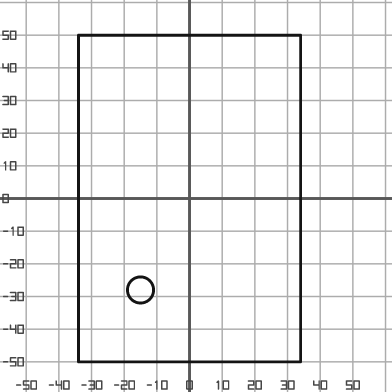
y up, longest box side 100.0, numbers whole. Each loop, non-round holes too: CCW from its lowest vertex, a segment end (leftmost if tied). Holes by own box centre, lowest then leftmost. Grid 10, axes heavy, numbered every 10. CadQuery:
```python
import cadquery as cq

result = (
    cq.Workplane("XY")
    .moveTo(-34.0, -50.0)
    .lineTo(34.0, -50.0)
    .lineTo(34.0, 50.0)
    .lineTo(-34.0, 50.0)
    .close()
    .moveTo(-15.0, -28.0)
    .circle(4.0)
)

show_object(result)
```